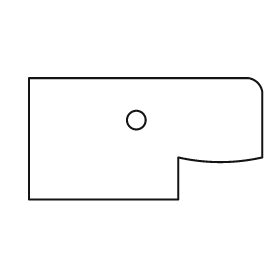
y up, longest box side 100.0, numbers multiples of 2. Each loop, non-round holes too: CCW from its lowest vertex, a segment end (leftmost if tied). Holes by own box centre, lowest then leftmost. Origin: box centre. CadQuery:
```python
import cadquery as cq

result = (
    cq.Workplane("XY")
    .moveTo(-50.0, -26.0)
    .lineTo(14.0, -26.0)
    .lineTo(14.0, -8.0)
    .threePointArc((32.0, -10.0), (50.0, -8.0))
    .lineTo(50.0, 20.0)
    .threePointArc((48.0, 24.0), (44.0, 26.0))
    .lineTo(-50.0, 26.0)
    .close()
    .moveTo(-4.0, 8.0)
    .circle(4.0)
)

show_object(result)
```